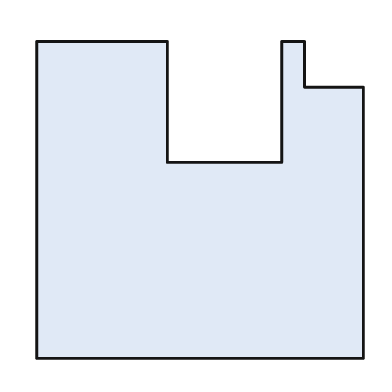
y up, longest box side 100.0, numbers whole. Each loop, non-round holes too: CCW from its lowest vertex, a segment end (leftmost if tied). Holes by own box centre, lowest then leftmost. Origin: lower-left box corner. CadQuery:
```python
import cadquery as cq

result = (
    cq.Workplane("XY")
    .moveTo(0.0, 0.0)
    .lineTo(100.0, 0.0)
    .lineTo(100.0, 83.0)
    .lineTo(82.0, 83.0)
    .lineTo(82.0, 97.0)
    .lineTo(75.0, 97.0)
    .lineTo(75.0, 60.0)
    .lineTo(40.0, 60.0)
    .lineTo(40.0, 97.0)
    .lineTo(0.0, 97.0)
    .close()
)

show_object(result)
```